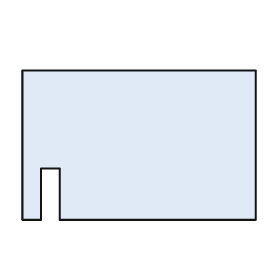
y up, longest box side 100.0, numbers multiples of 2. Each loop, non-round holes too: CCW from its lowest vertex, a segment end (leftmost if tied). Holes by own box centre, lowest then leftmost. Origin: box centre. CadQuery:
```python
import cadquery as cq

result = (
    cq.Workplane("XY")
    .moveTo(-50.0, -32.0)
    .lineTo(-42.0, -32.0)
    .lineTo(-42.0, -10.0)
    .lineTo(-34.0, -10.0)
    .lineTo(-34.0, -32.0)
    .lineTo(50.0, -32.0)
    .lineTo(50.0, 32.0)
    .lineTo(-50.0, 32.0)
    .close()
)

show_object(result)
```